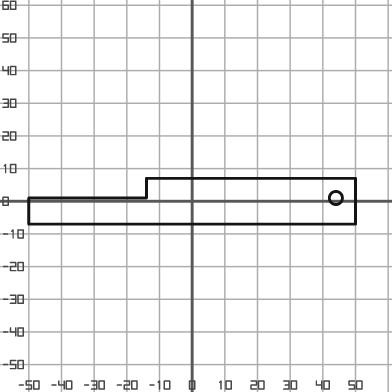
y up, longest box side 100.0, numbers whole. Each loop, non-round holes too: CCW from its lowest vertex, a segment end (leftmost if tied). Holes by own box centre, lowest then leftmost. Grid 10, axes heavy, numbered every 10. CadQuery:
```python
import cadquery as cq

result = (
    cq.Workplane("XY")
    .moveTo(-50.0, -7.0)
    .lineTo(50.0, -7.0)
    .lineTo(50.0, 7.0)
    .lineTo(-14.0, 7.0)
    .lineTo(-14.0, 1.0)
    .lineTo(-50.0, 1.0)
    .close()
    .moveTo(44.0, 1.0)
    .circle(2.0)
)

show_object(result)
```